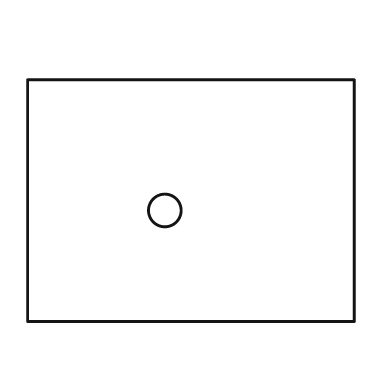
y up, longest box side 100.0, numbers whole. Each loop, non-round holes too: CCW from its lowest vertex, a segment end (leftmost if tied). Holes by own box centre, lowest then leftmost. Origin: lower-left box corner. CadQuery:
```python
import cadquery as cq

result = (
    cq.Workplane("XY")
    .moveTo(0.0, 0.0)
    .lineTo(100.0, 0.0)
    .lineTo(100.0, 74.0)
    .lineTo(0.0, 74.0)
    .close()
    .moveTo(42.0, 34.0)
    .circle(5.0)
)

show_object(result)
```